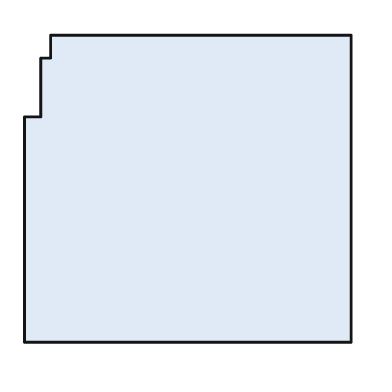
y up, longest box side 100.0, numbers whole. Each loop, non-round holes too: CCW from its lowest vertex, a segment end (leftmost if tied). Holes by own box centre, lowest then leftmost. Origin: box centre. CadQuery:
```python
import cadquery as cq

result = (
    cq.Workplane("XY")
    .moveTo(-50.0, -47.0)
    .lineTo(50.0, -47.0)
    .lineTo(50.0, 47.0)
    .lineTo(-42.0, 47.0)
    .lineTo(-42.0, 40.0)
    .lineTo(-45.0, 40.0)
    .lineTo(-45.0, 22.0)
    .lineTo(-50.0, 22.0)
    .close()
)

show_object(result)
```